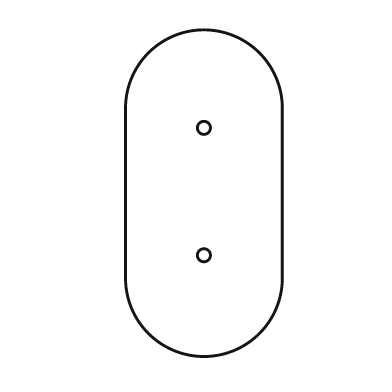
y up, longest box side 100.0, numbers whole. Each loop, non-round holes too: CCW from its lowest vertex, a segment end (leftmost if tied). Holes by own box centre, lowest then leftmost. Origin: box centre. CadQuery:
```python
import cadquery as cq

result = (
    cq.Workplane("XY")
    .moveTo(-24.0, -26.0)
    .threePointArc((0.0, -50.0), (24.0, -26.0))
    .lineTo(24.0, 26.0)
    .threePointArc((0.0, 50.0), (-24.0, 26.0))
    .close()
    .moveTo(0.0, -19.0)
    .circle(2.0)
    .moveTo(0.0, 20.0)
    .circle(2.0)
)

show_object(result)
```